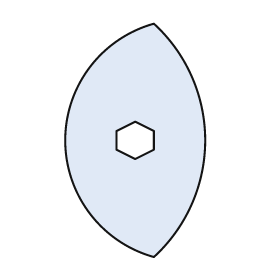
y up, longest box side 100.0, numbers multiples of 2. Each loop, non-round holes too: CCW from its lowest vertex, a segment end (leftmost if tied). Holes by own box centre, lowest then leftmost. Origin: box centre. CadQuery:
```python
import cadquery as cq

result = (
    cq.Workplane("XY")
    .moveTo(8.0, -50.0)
    .threePointArc((30.0, 0.0), (8.0, 50.0))
    .threePointArc((-30.0, 0.0), (8.0, -50.0))
    .close()
    .moveTo(0.0, -8.0)
    .lineTo(8.0, -4.0)
    .lineTo(8.0, 4.0)
    .lineTo(0.0, 8.0)
    .lineTo(-8.0, 4.0)
    .lineTo(-8.0, -4.0)
    .close()
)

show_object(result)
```